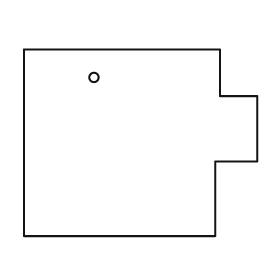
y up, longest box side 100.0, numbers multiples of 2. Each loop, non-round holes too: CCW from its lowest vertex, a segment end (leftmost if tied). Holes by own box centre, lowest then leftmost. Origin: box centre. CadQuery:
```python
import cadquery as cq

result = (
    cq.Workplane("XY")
    .moveTo(-50.0, -40.0)
    .lineTo(32.0, -40.0)
    .lineTo(32.0, -8.0)
    .lineTo(50.0, -8.0)
    .lineTo(50.0, 20.0)
    .lineTo(34.0, 20.0)
    .lineTo(34.0, 40.0)
    .lineTo(-50.0, 40.0)
    .close()
    .moveTo(-20.0, 28.0)
    .circle(2.0)
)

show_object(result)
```